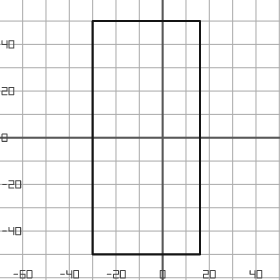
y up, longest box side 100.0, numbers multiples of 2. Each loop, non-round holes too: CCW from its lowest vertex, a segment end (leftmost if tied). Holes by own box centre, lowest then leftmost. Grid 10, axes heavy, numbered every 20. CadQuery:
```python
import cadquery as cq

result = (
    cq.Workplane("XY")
    .moveTo(-30.0, -50.0)
    .lineTo(16.0, -50.0)
    .lineTo(16.0, 50.0)
    .lineTo(-30.0, 50.0)
    .close()
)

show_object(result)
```